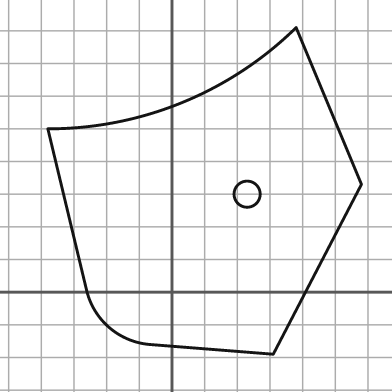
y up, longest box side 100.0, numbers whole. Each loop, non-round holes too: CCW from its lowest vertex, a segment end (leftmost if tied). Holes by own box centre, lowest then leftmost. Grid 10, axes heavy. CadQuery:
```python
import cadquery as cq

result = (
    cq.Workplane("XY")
    .moveTo(31.0, -19.0)
    .lineTo(58.0, 33.0)
    .lineTo(38.0, 81.0)
    .threePointArc((3.0, 58.0), (-38.0, 50.0))
    .lineTo(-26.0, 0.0)
    .threePointArc((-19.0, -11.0), (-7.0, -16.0))
    .close()
    .moveTo(23.0, 30.0)
    .circle(4.0)
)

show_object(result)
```